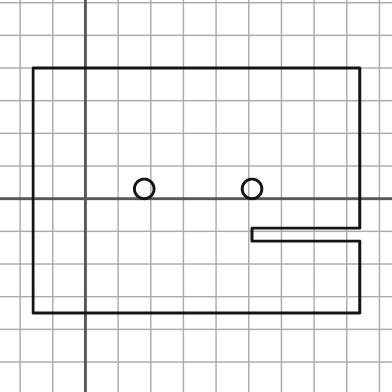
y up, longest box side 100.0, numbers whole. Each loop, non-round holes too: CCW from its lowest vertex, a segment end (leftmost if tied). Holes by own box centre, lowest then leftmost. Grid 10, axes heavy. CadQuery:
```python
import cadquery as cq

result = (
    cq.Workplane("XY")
    .moveTo(-16.0, -35.0)
    .lineTo(84.0, -35.0)
    .lineTo(84.0, -13.0)
    .lineTo(51.0, -13.0)
    .lineTo(51.0, -9.0)
    .lineTo(84.0, -9.0)
    .lineTo(84.0, 40.0)
    .lineTo(-16.0, 40.0)
    .close()
    .moveTo(18.0, 3.0)
    .circle(3.0)
    .moveTo(51.0, 3.0)
    .circle(3.0)
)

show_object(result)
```